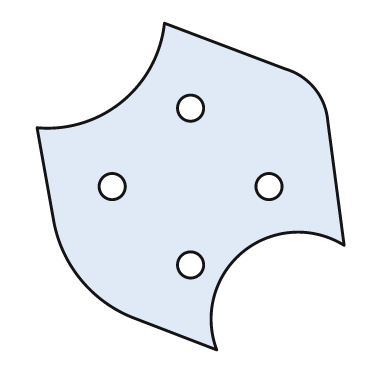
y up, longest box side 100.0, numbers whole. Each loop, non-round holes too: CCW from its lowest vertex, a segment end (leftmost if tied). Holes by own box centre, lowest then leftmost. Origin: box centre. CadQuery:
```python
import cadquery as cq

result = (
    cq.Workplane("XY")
    .moveTo(8.0, -50.0)
    .threePointArc((16.0, -20.0), (47.0, -18.0))
    .lineTo(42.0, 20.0)
    .threePointArc((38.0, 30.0), (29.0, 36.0))
    .lineTo(-8.0, 50.0)
    .threePointArc((-21.0, 26.0), (-47.0, 18.0))
    .lineTo(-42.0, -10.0)
    .threePointArc((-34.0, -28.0), (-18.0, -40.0))
    .close()
    .moveTo(0.0, -24.0)
    .circle(4.0)
    .moveTo(-24.0, 0.0)
    .circle(4.0)
    .moveTo(24.0, 0.0)
    .circle(4.0)
    .moveTo(0.0, 24.0)
    .circle(4.0)
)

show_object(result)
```